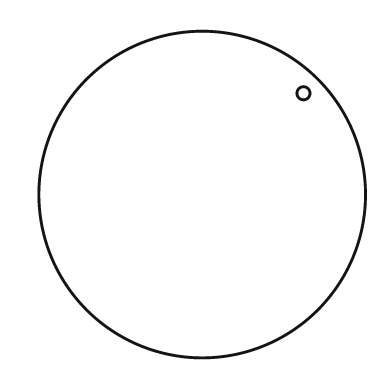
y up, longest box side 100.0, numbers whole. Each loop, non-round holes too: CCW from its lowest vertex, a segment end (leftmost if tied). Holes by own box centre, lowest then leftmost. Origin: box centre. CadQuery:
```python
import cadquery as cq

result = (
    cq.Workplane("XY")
    .moveTo(0.0, 0.0)
    .circle(50.0)
    .moveTo(31.0, 31.0)
    .circle(2.0)
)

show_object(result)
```